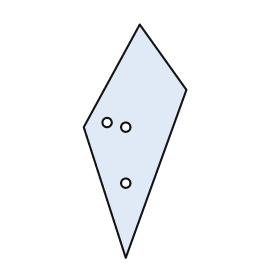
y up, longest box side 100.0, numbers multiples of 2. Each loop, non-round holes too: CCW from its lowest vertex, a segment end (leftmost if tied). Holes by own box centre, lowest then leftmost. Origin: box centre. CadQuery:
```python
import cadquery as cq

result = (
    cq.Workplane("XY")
    .moveTo(-4.0, -50.0)
    .lineTo(22.0, 22.0)
    .lineTo(2.0, 50.0)
    .lineTo(-22.0, 6.0)
    .close()
    .moveTo(-4.0, -18.0)
    .circle(2.0)
    .moveTo(-4.0, 6.0)
    .circle(2.0)
    .moveTo(-12.0, 8.0)
    .circle(2.0)
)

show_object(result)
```